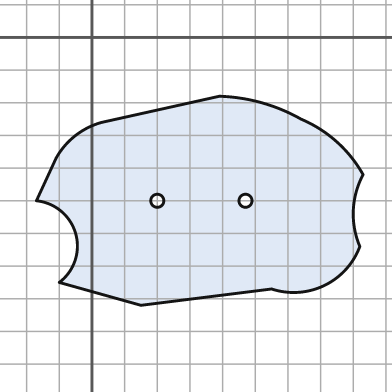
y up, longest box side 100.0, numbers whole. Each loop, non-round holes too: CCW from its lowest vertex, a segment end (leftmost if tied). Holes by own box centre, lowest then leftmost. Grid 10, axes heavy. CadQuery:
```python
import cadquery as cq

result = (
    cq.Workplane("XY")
    .moveTo(15.0, -82.0)
    .lineTo(55.0, -77.0)
    .threePointArc((71.0, -76.0), (82.0, -64.0))
    .threePointArc((80.0, -53.0), (83.0, -42.0))
    .threePointArc((75.0, -32.0), (64.0, -25.0))
    .threePointArc((52.0, -20.0), (39.0, -18.0))
    .lineTo(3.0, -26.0)
    .threePointArc((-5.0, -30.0), (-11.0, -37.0))
    .lineTo(-17.0, -50.0)
    .threePointArc((-5.0, -60.0), (-10.0, -75.0))
    .close()
    .moveTo(20.0, -50.0)
    .circle(2.0)
    .moveTo(47.0, -50.0)
    .circle(2.0)
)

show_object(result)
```